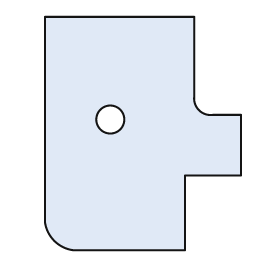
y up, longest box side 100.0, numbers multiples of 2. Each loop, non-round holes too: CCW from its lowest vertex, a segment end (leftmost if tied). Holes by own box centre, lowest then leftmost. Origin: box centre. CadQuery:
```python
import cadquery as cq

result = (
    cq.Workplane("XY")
    .moveTo(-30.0, -50.0)
    .lineTo(18.0, -50.0)
    .lineTo(18.0, -18.0)
    .lineTo(42.0, -18.0)
    .lineTo(42.0, 8.0)
    .lineTo(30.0, 8.0)
    .threePointArc((24.0, 10.0), (22.0, 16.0))
    .lineTo(22.0, 50.0)
    .lineTo(-42.0, 50.0)
    .lineTo(-42.0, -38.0)
    .threePointArc((-38.0, -46.0), (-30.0, -50.0))
    .close()
    .moveTo(-14.0, 6.0)
    .circle(6.0)
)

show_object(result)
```